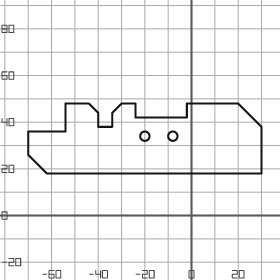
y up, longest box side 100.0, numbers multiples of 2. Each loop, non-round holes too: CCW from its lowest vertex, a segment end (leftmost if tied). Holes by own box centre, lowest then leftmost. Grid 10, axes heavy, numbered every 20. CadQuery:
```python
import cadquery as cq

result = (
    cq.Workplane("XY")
    .moveTo(-62.0, 18.0)
    .lineTo(30.0, 18.0)
    .lineTo(30.0, 38.0)
    .lineTo(20.0, 48.0)
    .lineTo(-2.0, 48.0)
    .lineTo(-2.0, 42.0)
    .lineTo(-24.0, 42.0)
    .lineTo(-24.0, 48.0)
    .lineTo(-30.0, 48.0)
    .lineTo(-34.0, 44.0)
    .lineTo(-34.0, 38.0)
    .lineTo(-40.0, 38.0)
    .lineTo(-40.0, 44.0)
    .lineTo(-44.0, 48.0)
    .lineTo(-54.0, 48.0)
    .lineTo(-54.0, 36.0)
    .lineTo(-70.0, 36.0)
    .lineTo(-70.0, 26.0)
    .close()
    .moveTo(-20.0, 34.0)
    .circle(2.0)
    .moveTo(-8.0, 34.0)
    .circle(2.0)
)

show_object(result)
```